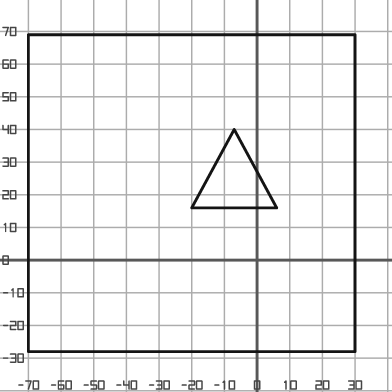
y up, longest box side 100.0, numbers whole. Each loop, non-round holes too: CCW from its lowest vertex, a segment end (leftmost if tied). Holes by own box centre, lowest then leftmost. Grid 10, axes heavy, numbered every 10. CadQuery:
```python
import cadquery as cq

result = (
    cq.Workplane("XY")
    .moveTo(-70.0, -28.0)
    .lineTo(30.0, -28.0)
    .lineTo(30.0, 69.0)
    .lineTo(-70.0, 69.0)
    .close()
    .moveTo(-20.0, 16.0)
    .lineTo(6.0, 16.0)
    .lineTo(-7.0, 40.0)
    .close()
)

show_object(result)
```